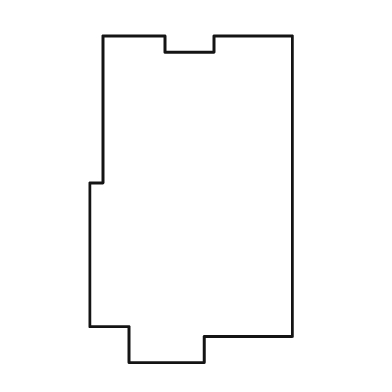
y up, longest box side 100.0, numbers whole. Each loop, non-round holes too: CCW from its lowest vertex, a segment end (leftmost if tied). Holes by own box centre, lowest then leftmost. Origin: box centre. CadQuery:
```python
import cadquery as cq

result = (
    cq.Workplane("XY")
    .moveTo(-19.0, -50.0)
    .lineTo(4.0, -50.0)
    .lineTo(4.0, -42.0)
    .lineTo(31.0, -42.0)
    .lineTo(31.0, 50.0)
    .lineTo(7.0, 50.0)
    .lineTo(7.0, 45.0)
    .lineTo(-8.0, 45.0)
    .lineTo(-8.0, 50.0)
    .lineTo(-27.0, 50.0)
    .lineTo(-27.0, 5.0)
    .lineTo(-31.0, 5.0)
    .lineTo(-31.0, -39.0)
    .lineTo(-19.0, -39.0)
    .close()
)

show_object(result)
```